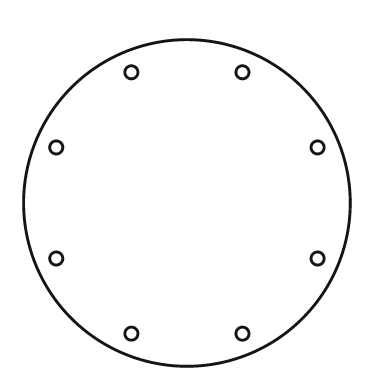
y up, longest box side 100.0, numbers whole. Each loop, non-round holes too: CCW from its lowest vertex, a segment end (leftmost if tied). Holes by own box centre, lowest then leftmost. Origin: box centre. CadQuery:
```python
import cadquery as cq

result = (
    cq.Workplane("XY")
    .moveTo(0.0, 0.0)
    .circle(50.0)
    .moveTo(-17.0, -40.0)
    .circle(2.0)
    .moveTo(17.0, -40.0)
    .circle(2.0)
    .moveTo(-40.0, -17.0)
    .circle(2.0)
    .moveTo(40.0, -17.0)
    .circle(2.0)
    .moveTo(-40.0, 17.0)
    .circle(2.0)
    .moveTo(40.0, 17.0)
    .circle(2.0)
    .moveTo(-17.0, 40.0)
    .circle(2.0)
    .moveTo(17.0, 40.0)
    .circle(2.0)
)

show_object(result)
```